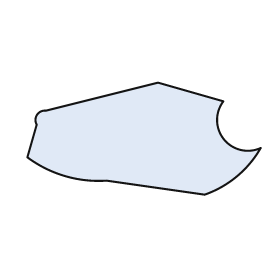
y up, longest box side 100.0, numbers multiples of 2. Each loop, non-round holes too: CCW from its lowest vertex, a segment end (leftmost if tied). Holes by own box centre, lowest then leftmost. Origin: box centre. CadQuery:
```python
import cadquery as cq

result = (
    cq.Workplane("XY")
    .moveTo(26.0, -24.0)
    .threePointArc((40.0, -16.0), (50.0, -4.0))
    .threePointArc((34.0, 0.0), (34.0, 16.0))
    .lineTo(6.0, 24.0)
    .lineTo(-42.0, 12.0)
    .threePointArc((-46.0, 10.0), (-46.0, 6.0))
    .lineTo(-50.0, -8.0)
    .threePointArc((-34.0, -16.0), (-16.0, -18.0))
    .close()
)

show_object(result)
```